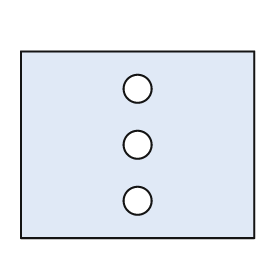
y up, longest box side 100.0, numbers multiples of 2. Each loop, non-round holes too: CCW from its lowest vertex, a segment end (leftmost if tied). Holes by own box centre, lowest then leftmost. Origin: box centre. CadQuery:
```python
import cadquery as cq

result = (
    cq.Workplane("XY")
    .moveTo(-50.0, -40.0)
    .lineTo(50.0, -40.0)
    .lineTo(50.0, 40.0)
    .lineTo(-50.0, 40.0)
    .close()
    .moveTo(0.0, -24.0)
    .circle(6.0)
    .moveTo(0.0, 0.0)
    .circle(6.0)
    .moveTo(0.0, 24.0)
    .circle(6.0)
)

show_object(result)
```